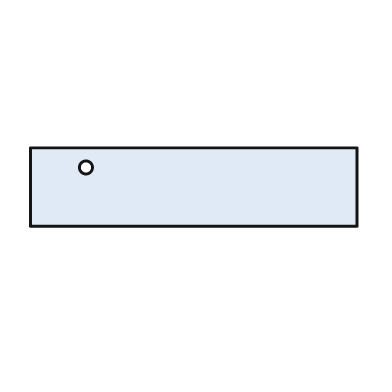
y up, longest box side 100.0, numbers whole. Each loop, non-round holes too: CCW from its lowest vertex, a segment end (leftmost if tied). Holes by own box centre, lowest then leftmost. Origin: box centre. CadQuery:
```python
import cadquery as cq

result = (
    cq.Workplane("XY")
    .moveTo(-50.0, -12.0)
    .lineTo(50.0, -12.0)
    .lineTo(50.0, 12.0)
    .lineTo(-50.0, 12.0)
    .close()
    .moveTo(-33.0, 6.0)
    .circle(2.0)
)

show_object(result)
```